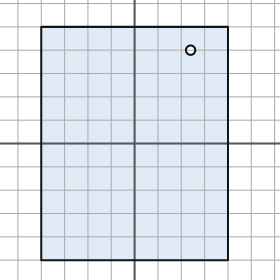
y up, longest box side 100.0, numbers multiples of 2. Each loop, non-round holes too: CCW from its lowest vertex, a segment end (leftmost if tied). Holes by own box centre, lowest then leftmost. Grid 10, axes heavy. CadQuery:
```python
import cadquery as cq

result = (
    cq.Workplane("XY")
    .moveTo(-40.0, -50.0)
    .lineTo(40.0, -50.0)
    .lineTo(40.0, 50.0)
    .lineTo(-40.0, 50.0)
    .close()
    .moveTo(24.0, 40.0)
    .circle(2.0)
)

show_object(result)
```